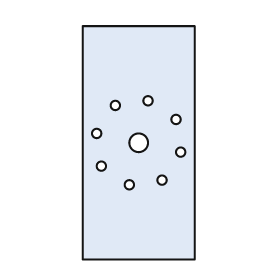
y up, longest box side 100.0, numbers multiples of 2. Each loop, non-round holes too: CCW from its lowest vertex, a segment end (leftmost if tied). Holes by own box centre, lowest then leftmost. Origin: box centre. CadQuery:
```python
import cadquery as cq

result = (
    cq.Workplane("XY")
    .moveTo(-24.0, -50.0)
    .lineTo(24.0, -50.0)
    .lineTo(24.0, 50.0)
    .lineTo(-24.0, 50.0)
    .close()
    .moveTo(-4.0, -18.0)
    .circle(2.0)
    .moveTo(10.0, -16.0)
    .circle(2.0)
    .moveTo(-16.0, -10.0)
    .circle(2.0)
    .moveTo(18.0, -4.0)
    .circle(2.0)
    .moveTo(0.0, 0.0)
    .circle(4.0)
    .moveTo(-18.0, 4.0)
    .circle(2.0)
    .moveTo(16.0, 10.0)
    .circle(2.0)
    .moveTo(-10.0, 16.0)
    .circle(2.0)
    .moveTo(4.0, 18.0)
    .circle(2.0)
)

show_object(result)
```